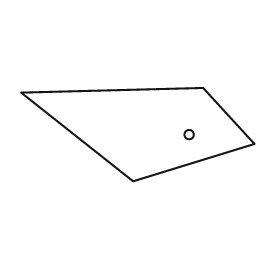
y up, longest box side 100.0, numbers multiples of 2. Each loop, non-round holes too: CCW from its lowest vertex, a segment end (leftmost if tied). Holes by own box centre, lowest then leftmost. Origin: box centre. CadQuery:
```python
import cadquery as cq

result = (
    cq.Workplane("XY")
    .moveTo(-2.0, -20.0)
    .lineTo(50.0, -4.0)
    .lineTo(28.0, 20.0)
    .lineTo(-50.0, 18.0)
    .close()
    .moveTo(22.0, 0.0)
    .circle(2.0)
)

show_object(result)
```